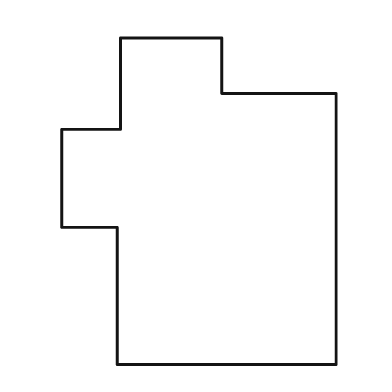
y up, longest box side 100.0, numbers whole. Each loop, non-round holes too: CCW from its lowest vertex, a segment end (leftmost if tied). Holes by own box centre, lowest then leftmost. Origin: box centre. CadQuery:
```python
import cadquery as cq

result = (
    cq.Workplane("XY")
    .moveTo(-25.0, -50.0)
    .lineTo(42.0, -50.0)
    .lineTo(42.0, 33.0)
    .lineTo(7.0, 33.0)
    .lineTo(7.0, 50.0)
    .lineTo(-24.0, 50.0)
    .lineTo(-24.0, 22.0)
    .lineTo(-42.0, 22.0)
    .lineTo(-42.0, -8.0)
    .lineTo(-25.0, -8.0)
    .close()
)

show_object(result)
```